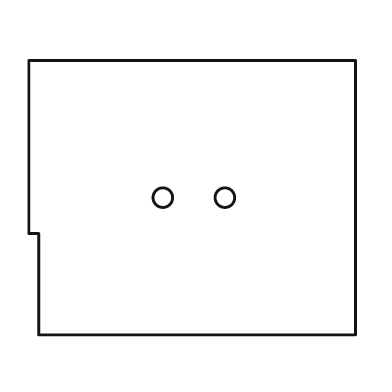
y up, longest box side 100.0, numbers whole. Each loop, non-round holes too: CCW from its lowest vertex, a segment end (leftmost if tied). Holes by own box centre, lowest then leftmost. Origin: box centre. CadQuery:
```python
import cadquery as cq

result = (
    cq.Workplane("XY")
    .moveTo(-47.0, -42.0)
    .lineTo(50.0, -42.0)
    .lineTo(50.0, 42.0)
    .lineTo(-50.0, 42.0)
    .lineTo(-50.0, -11.0)
    .lineTo(-47.0, -11.0)
    .close()
    .moveTo(-9.0, 0.0)
    .circle(3.0)
    .moveTo(10.0, 0.0)
    .circle(3.0)
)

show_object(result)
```